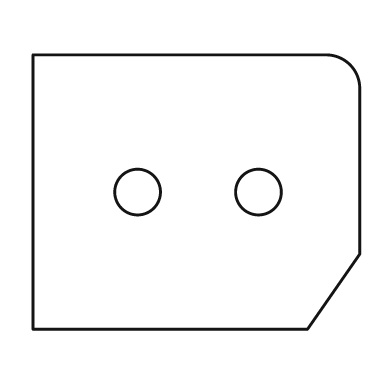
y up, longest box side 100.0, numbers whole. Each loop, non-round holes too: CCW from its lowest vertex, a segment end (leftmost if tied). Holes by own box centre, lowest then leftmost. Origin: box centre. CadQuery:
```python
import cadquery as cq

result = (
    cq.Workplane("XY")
    .moveTo(-50.0, -42.0)
    .lineTo(34.0, -42.0)
    .lineTo(50.0, -19.0)
    .lineTo(50.0, 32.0)
    .threePointArc((47.0, 39.0), (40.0, 42.0))
    .lineTo(-50.0, 42.0)
    .close()
    .moveTo(-18.0, 0.0)
    .circle(7.0)
    .moveTo(19.0, 0.0)
    .circle(7.0)
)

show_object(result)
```